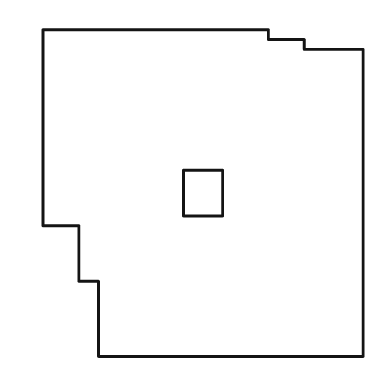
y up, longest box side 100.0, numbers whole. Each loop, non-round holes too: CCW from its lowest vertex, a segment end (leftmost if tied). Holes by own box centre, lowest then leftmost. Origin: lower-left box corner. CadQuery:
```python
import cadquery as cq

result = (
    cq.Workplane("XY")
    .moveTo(17.0, 0.0)
    .lineTo(98.0, 0.0)
    .lineTo(98.0, 94.0)
    .lineTo(80.0, 94.0)
    .lineTo(80.0, 97.0)
    .lineTo(69.0, 97.0)
    .lineTo(69.0, 100.0)
    .lineTo(0.0, 100.0)
    .lineTo(0.0, 40.0)
    .lineTo(11.0, 40.0)
    .lineTo(11.0, 23.0)
    .lineTo(17.0, 23.0)
    .close()
    .moveTo(43.0, 43.0)
    .lineTo(55.0, 43.0)
    .lineTo(55.0, 57.0)
    .lineTo(43.0, 57.0)
    .close()
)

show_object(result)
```